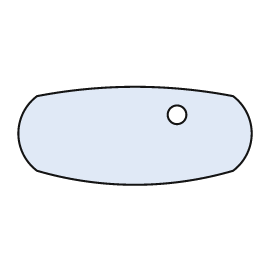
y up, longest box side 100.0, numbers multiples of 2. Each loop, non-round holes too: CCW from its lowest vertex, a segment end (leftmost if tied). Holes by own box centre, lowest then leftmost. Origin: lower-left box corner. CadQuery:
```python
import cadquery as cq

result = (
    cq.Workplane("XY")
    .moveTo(8.0, 6.0)
    .threePointArc((50.0, 0.0), (92.0, 6.0))
    .threePointArc((100.0, 22.0), (92.0, 38.0))
    .threePointArc((50.0, 42.0), (8.0, 38.0))
    .threePointArc((0.0, 22.0), (8.0, 6.0))
    .close()
    .moveTo(68.0, 30.0)
    .circle(4.0)
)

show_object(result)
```